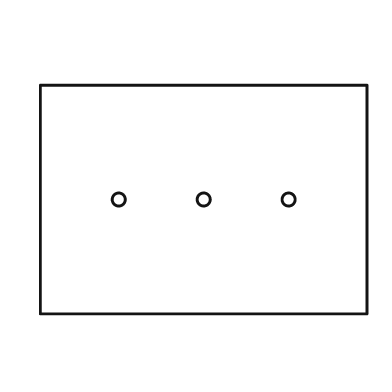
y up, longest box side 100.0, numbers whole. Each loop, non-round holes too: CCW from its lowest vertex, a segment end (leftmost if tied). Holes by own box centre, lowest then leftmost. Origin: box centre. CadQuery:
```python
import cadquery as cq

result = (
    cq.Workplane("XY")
    .moveTo(-50.0, -35.0)
    .lineTo(50.0, -35.0)
    .lineTo(50.0, 35.0)
    .lineTo(-50.0, 35.0)
    .close()
    .moveTo(-26.0, 0.0)
    .circle(2.0)
    .moveTo(0.0, 0.0)
    .circle(2.0)
    .moveTo(26.0, 0.0)
    .circle(2.0)
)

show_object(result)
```